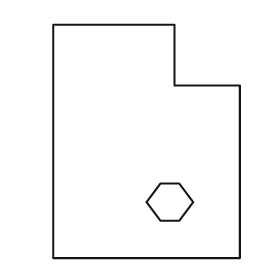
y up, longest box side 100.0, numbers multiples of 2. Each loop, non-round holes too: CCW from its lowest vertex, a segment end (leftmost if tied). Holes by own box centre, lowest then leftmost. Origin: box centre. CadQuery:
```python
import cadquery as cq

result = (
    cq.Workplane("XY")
    .moveTo(-40.0, -50.0)
    .lineTo(40.0, -50.0)
    .lineTo(40.0, 24.0)
    .lineTo(12.0, 24.0)
    .lineTo(12.0, 50.0)
    .lineTo(-40.0, 50.0)
    .close()
    .moveTo(6.0, -34.0)
    .lineTo(14.0, -34.0)
    .lineTo(20.0, -26.0)
    .lineTo(14.0, -18.0)
    .lineTo(6.0, -18.0)
    .lineTo(0.0, -26.0)
    .close()
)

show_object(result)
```